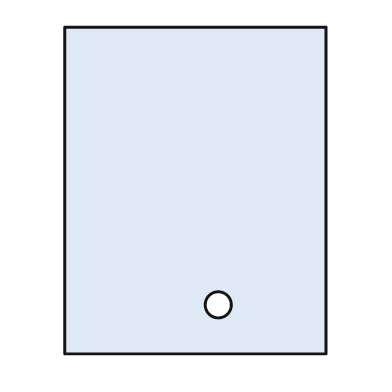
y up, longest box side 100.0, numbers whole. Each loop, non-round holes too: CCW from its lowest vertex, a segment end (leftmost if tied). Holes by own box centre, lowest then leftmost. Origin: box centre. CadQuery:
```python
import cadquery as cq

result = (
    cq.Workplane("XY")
    .moveTo(-40.0, -50.0)
    .lineTo(40.0, -50.0)
    .lineTo(40.0, 50.0)
    .lineTo(-40.0, 50.0)
    .close()
    .moveTo(7.0, -35.0)
    .circle(4.0)
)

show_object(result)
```